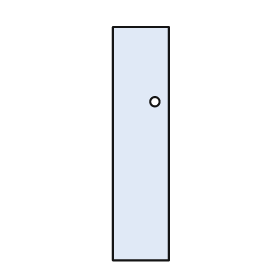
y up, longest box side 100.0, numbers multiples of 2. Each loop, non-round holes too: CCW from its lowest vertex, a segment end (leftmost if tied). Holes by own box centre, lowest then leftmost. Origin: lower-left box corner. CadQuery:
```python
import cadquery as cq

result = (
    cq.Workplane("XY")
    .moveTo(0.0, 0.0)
    .lineTo(24.0, 0.0)
    .lineTo(24.0, 100.0)
    .lineTo(0.0, 100.0)
    .close()
    .moveTo(18.0, 68.0)
    .circle(2.0)
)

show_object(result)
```